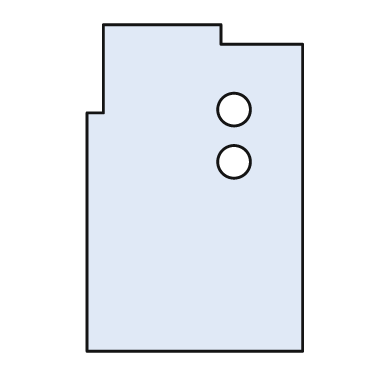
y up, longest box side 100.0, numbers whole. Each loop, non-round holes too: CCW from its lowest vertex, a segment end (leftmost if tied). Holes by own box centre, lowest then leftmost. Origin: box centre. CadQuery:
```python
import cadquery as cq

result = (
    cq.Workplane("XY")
    .moveTo(-33.0, -50.0)
    .lineTo(33.0, -50.0)
    .lineTo(33.0, 44.0)
    .lineTo(8.0, 44.0)
    .lineTo(8.0, 50.0)
    .lineTo(-28.0, 50.0)
    .lineTo(-28.0, 23.0)
    .lineTo(-33.0, 23.0)
    .close()
    .moveTo(12.0, 8.0)
    .circle(5.0)
    .moveTo(12.0, 24.0)
    .circle(5.0)
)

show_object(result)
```